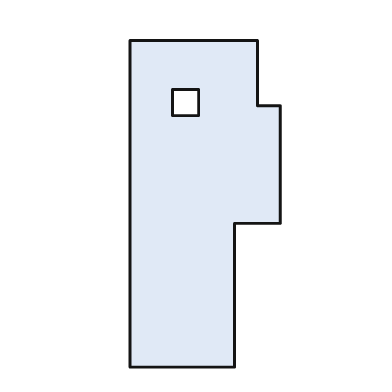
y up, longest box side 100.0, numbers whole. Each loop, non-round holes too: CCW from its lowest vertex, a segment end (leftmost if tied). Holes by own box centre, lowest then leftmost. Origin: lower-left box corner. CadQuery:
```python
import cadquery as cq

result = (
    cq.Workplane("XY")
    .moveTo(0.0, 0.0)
    .lineTo(32.0, 0.0)
    .lineTo(32.0, 44.0)
    .lineTo(46.0, 44.0)
    .lineTo(46.0, 80.0)
    .lineTo(39.0, 80.0)
    .lineTo(39.0, 100.0)
    .lineTo(0.0, 100.0)
    .close()
    .moveTo(13.0, 77.0)
    .lineTo(21.0, 77.0)
    .lineTo(21.0, 85.0)
    .lineTo(13.0, 85.0)
    .close()
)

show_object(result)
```